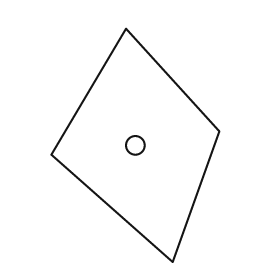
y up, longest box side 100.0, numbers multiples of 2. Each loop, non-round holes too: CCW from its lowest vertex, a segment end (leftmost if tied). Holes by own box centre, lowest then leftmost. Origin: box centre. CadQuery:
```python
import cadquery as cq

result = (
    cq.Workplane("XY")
    .moveTo(16.0, -50.0)
    .lineTo(36.0, 6.0)
    .lineTo(-4.0, 50.0)
    .lineTo(-36.0, -4.0)
    .close()
    .moveTo(0.0, 0.0)
    .circle(4.0)
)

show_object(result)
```